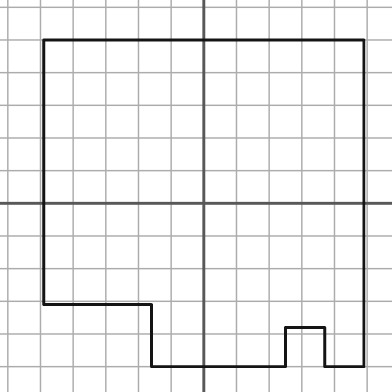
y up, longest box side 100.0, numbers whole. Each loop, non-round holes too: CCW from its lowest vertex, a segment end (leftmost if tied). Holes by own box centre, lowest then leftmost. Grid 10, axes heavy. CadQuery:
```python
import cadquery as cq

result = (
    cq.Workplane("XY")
    .moveTo(-16.0, -50.0)
    .lineTo(25.0, -50.0)
    .lineTo(25.0, -38.0)
    .lineTo(37.0, -38.0)
    .lineTo(37.0, -50.0)
    .lineTo(49.0, -50.0)
    .lineTo(49.0, 50.0)
    .lineTo(-49.0, 50.0)
    .lineTo(-49.0, -31.0)
    .lineTo(-16.0, -31.0)
    .close()
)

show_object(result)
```